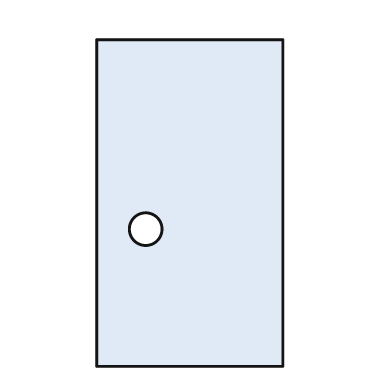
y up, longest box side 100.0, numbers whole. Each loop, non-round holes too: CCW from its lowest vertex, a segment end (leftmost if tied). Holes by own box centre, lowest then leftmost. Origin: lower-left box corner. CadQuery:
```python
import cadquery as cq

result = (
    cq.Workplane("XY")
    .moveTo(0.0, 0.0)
    .lineTo(57.0, 0.0)
    .lineTo(57.0, 100.0)
    .lineTo(0.0, 100.0)
    .close()
    .moveTo(15.0, 42.0)
    .circle(5.0)
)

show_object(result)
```